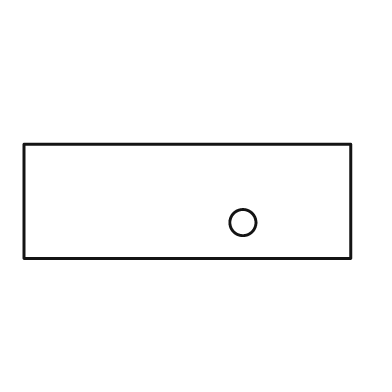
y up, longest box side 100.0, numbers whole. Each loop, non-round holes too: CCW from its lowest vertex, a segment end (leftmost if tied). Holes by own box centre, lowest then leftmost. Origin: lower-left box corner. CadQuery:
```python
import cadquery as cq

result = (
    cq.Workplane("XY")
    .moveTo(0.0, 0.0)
    .lineTo(100.0, 0.0)
    .lineTo(100.0, 35.0)
    .lineTo(0.0, 35.0)
    .close()
    .moveTo(67.0, 11.0)
    .circle(4.0)
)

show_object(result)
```